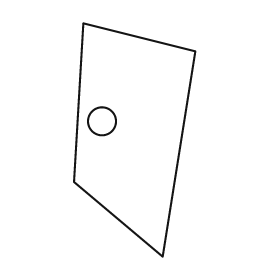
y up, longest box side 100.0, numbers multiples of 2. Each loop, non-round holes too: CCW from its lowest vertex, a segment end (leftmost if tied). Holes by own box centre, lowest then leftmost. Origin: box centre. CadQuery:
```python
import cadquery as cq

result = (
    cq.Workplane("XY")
    .moveTo(12.0, -50.0)
    .lineTo(26.0, 38.0)
    .lineTo(-22.0, 50.0)
    .lineTo(-26.0, -18.0)
    .close()
    .moveTo(-14.0, 8.0)
    .circle(6.0)
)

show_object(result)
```